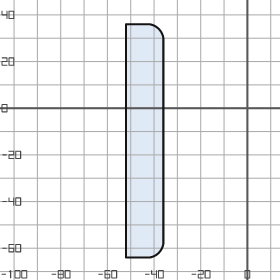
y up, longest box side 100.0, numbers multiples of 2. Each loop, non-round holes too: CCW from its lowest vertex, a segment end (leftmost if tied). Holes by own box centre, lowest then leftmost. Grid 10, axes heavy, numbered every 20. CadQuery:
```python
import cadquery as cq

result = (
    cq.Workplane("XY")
    .moveTo(-52.0, -64.0)
    .lineTo(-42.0, -64.0)
    .threePointArc((-38.0, -62.0), (-36.0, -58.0))
    .lineTo(-36.0, 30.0)
    .threePointArc((-38.0, 34.0), (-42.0, 36.0))
    .lineTo(-52.0, 36.0)
    .close()
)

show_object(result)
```